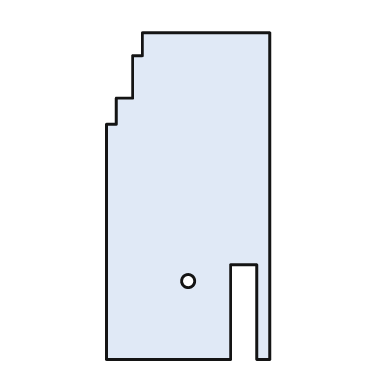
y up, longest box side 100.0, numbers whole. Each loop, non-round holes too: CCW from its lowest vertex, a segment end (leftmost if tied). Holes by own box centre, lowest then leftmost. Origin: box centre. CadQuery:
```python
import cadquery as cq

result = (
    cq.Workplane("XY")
    .moveTo(-25.0, -50.0)
    .lineTo(13.0, -50.0)
    .lineTo(13.0, -21.0)
    .lineTo(21.0, -21.0)
    .lineTo(21.0, -50.0)
    .lineTo(25.0, -50.0)
    .lineTo(25.0, 50.0)
    .lineTo(-14.0, 50.0)
    .lineTo(-14.0, 43.0)
    .lineTo(-17.0, 43.0)
    .lineTo(-17.0, 30.0)
    .lineTo(-22.0, 30.0)
    .lineTo(-22.0, 22.0)
    .lineTo(-25.0, 22.0)
    .close()
    .moveTo(0.0, -26.0)
    .circle(2.0)
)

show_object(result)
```